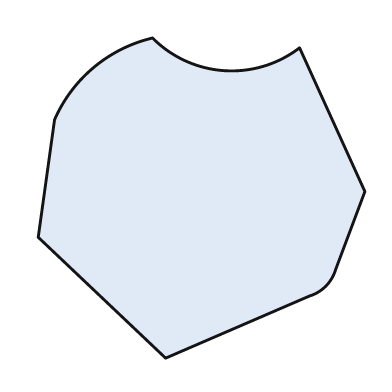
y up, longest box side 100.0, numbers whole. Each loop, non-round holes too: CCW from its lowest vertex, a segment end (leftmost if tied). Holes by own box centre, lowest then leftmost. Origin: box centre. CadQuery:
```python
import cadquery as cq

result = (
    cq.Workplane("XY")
    .moveTo(-11.0, -49.0)
    .lineTo(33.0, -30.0)
    .threePointArc((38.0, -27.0), (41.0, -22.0))
    .lineTo(50.0, 2.0)
    .lineTo(30.0, 46.0)
    .threePointArc((7.0, 39.0), (-15.0, 49.0))
    .threePointArc((-33.0, 40.0), (-45.0, 24.0))
    .lineTo(-50.0, -12.0)
    .close()
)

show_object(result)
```